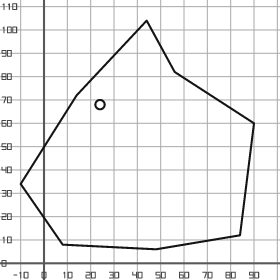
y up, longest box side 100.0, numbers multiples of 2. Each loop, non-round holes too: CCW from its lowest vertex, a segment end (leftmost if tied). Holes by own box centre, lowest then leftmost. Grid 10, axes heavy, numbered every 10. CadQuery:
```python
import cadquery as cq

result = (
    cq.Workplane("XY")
    .moveTo(48.0, 6.0)
    .lineTo(84.0, 12.0)
    .lineTo(90.0, 60.0)
    .lineTo(56.0, 82.0)
    .lineTo(44.0, 104.0)
    .lineTo(14.0, 72.0)
    .lineTo(-10.0, 34.0)
    .lineTo(8.0, 8.0)
    .close()
    .moveTo(24.0, 68.0)
    .circle(2.0)
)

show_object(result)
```